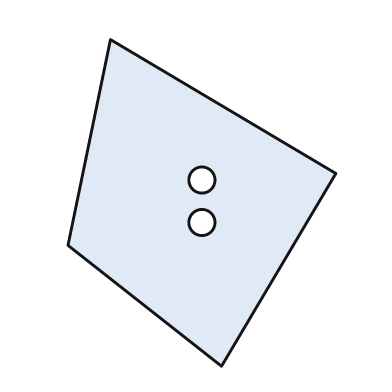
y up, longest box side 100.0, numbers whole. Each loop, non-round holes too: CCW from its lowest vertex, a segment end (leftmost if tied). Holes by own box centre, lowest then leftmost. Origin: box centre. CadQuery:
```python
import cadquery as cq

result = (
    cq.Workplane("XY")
    .moveTo(6.0, -50.0)
    .lineTo(41.0, 9.0)
    .lineTo(-28.0, 50.0)
    .lineTo(-41.0, -13.0)
    .close()
    .moveTo(0.0, -6.0)
    .circle(4.0)
    .moveTo(0.0, 7.0)
    .circle(4.0)
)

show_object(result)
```